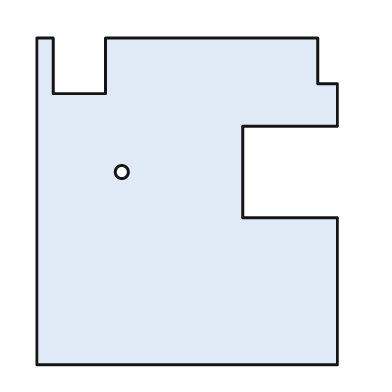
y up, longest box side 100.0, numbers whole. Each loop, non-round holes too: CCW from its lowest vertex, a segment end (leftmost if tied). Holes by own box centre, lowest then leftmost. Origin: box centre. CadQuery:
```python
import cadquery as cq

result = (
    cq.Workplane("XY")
    .moveTo(-46.0, -50.0)
    .lineTo(46.0, -50.0)
    .lineTo(46.0, -5.0)
    .lineTo(17.0, -5.0)
    .lineTo(17.0, 23.0)
    .lineTo(46.0, 23.0)
    .lineTo(46.0, 36.0)
    .lineTo(40.0, 36.0)
    .lineTo(40.0, 50.0)
    .lineTo(-25.0, 50.0)
    .lineTo(-25.0, 33.0)
    .lineTo(-41.0, 33.0)
    .lineTo(-41.0, 50.0)
    .lineTo(-46.0, 50.0)
    .close()
    .moveTo(-20.0, 9.0)
    .circle(2.0)
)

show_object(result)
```